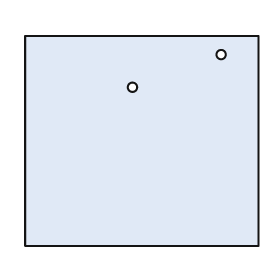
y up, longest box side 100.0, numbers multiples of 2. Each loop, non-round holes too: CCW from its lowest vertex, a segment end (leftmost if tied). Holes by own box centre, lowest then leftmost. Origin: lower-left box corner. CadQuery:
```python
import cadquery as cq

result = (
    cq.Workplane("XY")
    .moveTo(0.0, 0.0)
    .lineTo(100.0, 0.0)
    .lineTo(100.0, 90.0)
    .lineTo(0.0, 90.0)
    .close()
    .moveTo(46.0, 68.0)
    .circle(2.0)
    .moveTo(84.0, 82.0)
    .circle(2.0)
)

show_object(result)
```